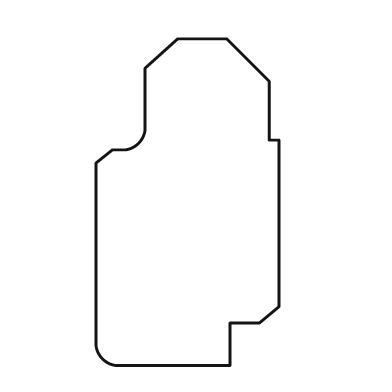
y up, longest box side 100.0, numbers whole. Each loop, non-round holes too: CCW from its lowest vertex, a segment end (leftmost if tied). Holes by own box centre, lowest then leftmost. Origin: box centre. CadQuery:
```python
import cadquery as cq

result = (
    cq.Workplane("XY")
    .moveTo(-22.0, -50.0)
    .lineTo(13.0, -50.0)
    .lineTo(13.0, -37.0)
    .lineTo(22.0, -37.0)
    .lineTo(28.0, -32.0)
    .lineTo(28.0, 19.0)
    .lineTo(25.0, 19.0)
    .lineTo(25.0, 37.0)
    .lineTo(12.0, 50.0)
    .lineTo(-3.0, 50.0)
    .lineTo(-13.0, 41.0)
    .lineTo(-13.0, 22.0)
    .threePointArc((-15.0, 18.0), (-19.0, 16.0))
    .lineTo(-23.0, 16.0)
    .lineTo(-28.0, 12.0)
    .lineTo(-28.0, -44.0)
    .threePointArc((-26.0, -48.0), (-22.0, -50.0))
    .close()
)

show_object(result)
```